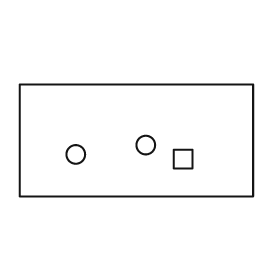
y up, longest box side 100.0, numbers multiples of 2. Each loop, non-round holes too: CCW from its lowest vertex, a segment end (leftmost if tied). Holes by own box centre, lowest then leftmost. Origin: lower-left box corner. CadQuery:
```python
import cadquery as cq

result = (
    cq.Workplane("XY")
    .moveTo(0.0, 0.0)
    .lineTo(100.0, 0.0)
    .lineTo(100.0, 48.0)
    .lineTo(0.0, 48.0)
    .close()
    .moveTo(66.0, 12.0)
    .lineTo(74.0, 12.0)
    .lineTo(74.0, 20.0)
    .lineTo(66.0, 20.0)
    .close()
    .moveTo(24.0, 18.0)
    .circle(4.0)
    .moveTo(54.0, 22.0)
    .circle(4.0)
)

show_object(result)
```